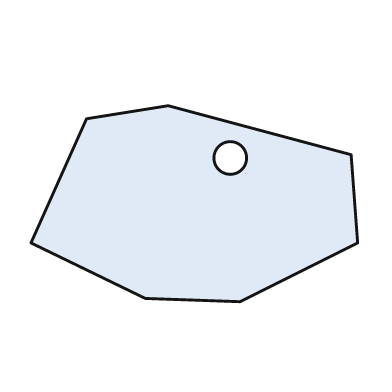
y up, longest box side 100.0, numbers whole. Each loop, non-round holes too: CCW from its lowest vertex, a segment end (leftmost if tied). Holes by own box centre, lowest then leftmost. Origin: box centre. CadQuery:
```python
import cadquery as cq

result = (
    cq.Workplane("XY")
    .moveTo(14.0, -30.0)
    .lineTo(50.0, -12.0)
    .lineTo(48.0, 15.0)
    .lineTo(-8.0, 30.0)
    .lineTo(-33.0, 26.0)
    .lineTo(-50.0, -12.0)
    .lineTo(-15.0, -29.0)
    .close()
    .moveTo(11.0, 14.0)
    .circle(5.0)
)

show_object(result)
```